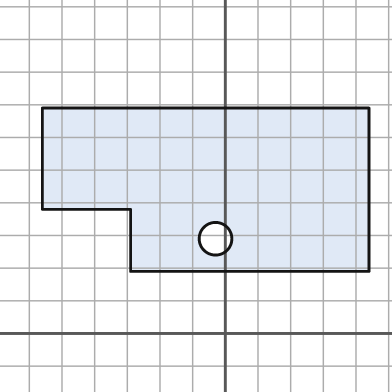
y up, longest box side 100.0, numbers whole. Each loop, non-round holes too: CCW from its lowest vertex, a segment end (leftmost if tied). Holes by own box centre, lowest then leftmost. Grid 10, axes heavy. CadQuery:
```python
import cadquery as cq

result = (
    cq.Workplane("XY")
    .moveTo(-29.0, 19.0)
    .lineTo(44.0, 19.0)
    .lineTo(44.0, 69.0)
    .lineTo(-56.0, 69.0)
    .lineTo(-56.0, 38.0)
    .lineTo(-29.0, 38.0)
    .close()
    .moveTo(-3.0, 29.0)
    .circle(5.0)
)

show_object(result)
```